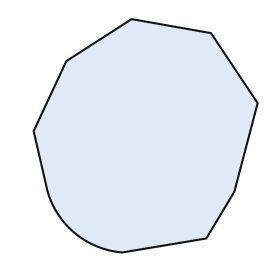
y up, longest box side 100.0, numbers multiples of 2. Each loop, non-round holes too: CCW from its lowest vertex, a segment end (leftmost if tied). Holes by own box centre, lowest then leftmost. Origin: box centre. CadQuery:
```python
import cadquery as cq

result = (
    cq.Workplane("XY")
    .moveTo(-10.0, -50.0)
    .lineTo(26.0, -44.0)
    .lineTo(38.0, -24.0)
    .lineTo(48.0, 14.0)
    .lineTo(28.0, 44.0)
    .lineTo(-6.0, 50.0)
    .lineTo(-34.0, 32.0)
    .lineTo(-48.0, 2.0)
    .lineTo(-42.0, -24.0)
    .threePointArc((-30.0, -42.0), (-10.0, -50.0))
    .close()
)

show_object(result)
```